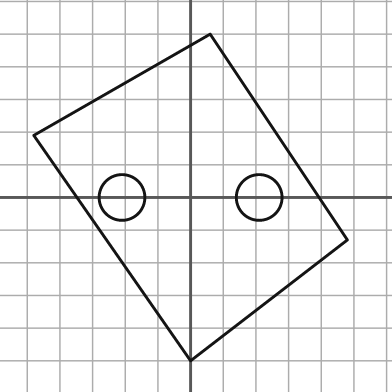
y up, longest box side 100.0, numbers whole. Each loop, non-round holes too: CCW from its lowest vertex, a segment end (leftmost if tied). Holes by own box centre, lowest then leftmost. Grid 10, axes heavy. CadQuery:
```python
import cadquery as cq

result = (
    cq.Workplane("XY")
    .moveTo(0.0, -50.0)
    .lineTo(48.0, -13.0)
    .lineTo(6.0, 50.0)
    .lineTo(-48.0, 19.0)
    .close()
    .moveTo(-21.0, 0.0)
    .circle(7.0)
    .moveTo(21.0, 0.0)
    .circle(7.0)
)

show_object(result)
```